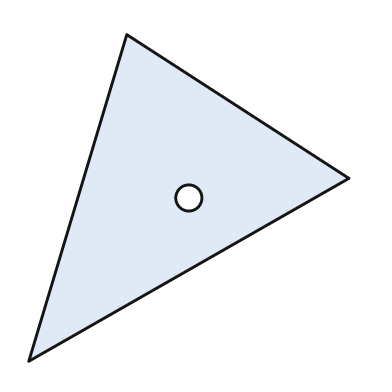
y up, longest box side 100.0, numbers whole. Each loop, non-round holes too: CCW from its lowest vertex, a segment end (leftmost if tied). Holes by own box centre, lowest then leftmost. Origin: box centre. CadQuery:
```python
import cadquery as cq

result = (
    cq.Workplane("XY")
    .moveTo(-49.0, -50.0)
    .lineTo(49.0, 6.0)
    .lineTo(-19.0, 50.0)
    .close()
    .moveTo(0.0, 0.0)
    .circle(4.0)
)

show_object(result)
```